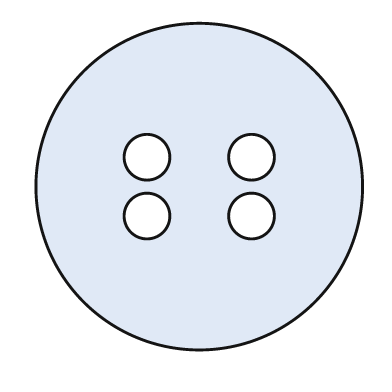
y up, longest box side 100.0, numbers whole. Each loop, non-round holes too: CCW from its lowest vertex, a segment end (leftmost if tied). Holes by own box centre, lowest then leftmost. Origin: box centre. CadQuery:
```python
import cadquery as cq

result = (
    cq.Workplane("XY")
    .moveTo(0.0, 0.0)
    .circle(50.0)
    .moveTo(-16.0, -9.0)
    .circle(7.0)
    .moveTo(16.0, -9.0)
    .circle(7.0)
    .moveTo(-16.0, 9.0)
    .circle(7.0)
    .moveTo(16.0, 9.0)
    .circle(7.0)
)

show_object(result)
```